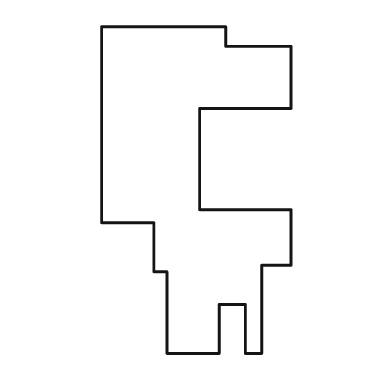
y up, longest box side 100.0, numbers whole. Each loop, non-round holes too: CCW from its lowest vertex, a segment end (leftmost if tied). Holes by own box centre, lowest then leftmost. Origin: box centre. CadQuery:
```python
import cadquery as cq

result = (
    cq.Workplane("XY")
    .moveTo(-9.0, -50.0)
    .lineTo(7.0, -50.0)
    .lineTo(7.0, -35.0)
    .lineTo(15.0, -35.0)
    .lineTo(15.0, -50.0)
    .lineTo(20.0, -50.0)
    .lineTo(20.0, -23.0)
    .lineTo(29.0, -23.0)
    .lineTo(29.0, -6.0)
    .lineTo(1.0, -6.0)
    .lineTo(1.0, 25.0)
    .lineTo(29.0, 25.0)
    .lineTo(29.0, 44.0)
    .lineTo(9.0, 44.0)
    .lineTo(9.0, 50.0)
    .lineTo(-29.0, 50.0)
    .lineTo(-29.0, -10.0)
    .lineTo(-13.0, -10.0)
    .lineTo(-13.0, -25.0)
    .lineTo(-9.0, -25.0)
    .close()
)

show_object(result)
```